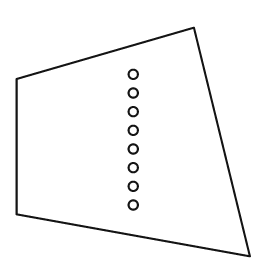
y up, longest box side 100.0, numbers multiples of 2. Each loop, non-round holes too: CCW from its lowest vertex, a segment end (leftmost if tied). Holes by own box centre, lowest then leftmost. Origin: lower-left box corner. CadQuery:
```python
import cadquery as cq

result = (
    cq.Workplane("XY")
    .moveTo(100.0, 0.0)
    .lineTo(76.0, 98.0)
    .lineTo(0.0, 76.0)
    .lineTo(0.0, 18.0)
    .close()
    .moveTo(50.0, 22.0)
    .circle(2.0)
    .moveTo(50.0, 30.0)
    .circle(2.0)
    .moveTo(50.0, 38.0)
    .circle(2.0)
    .moveTo(50.0, 46.0)
    .circle(2.0)
    .moveTo(50.0, 54.0)
    .circle(2.0)
    .moveTo(50.0, 62.0)
    .circle(2.0)
    .moveTo(50.0, 70.0)
    .circle(2.0)
    .moveTo(50.0, 78.0)
    .circle(2.0)
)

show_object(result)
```